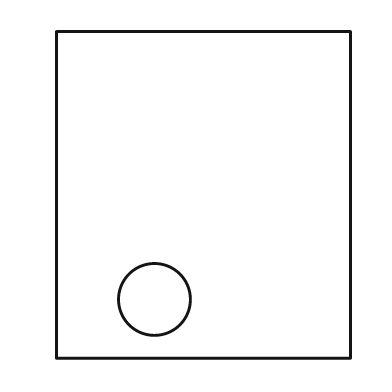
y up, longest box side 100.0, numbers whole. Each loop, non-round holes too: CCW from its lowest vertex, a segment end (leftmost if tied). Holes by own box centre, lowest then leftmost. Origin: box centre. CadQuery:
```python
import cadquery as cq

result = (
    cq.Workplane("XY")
    .moveTo(-45.0, -50.0)
    .lineTo(45.0, -50.0)
    .lineTo(45.0, 50.0)
    .lineTo(-45.0, 50.0)
    .close()
    .moveTo(-15.0, -32.0)
    .circle(11.0)
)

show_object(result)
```